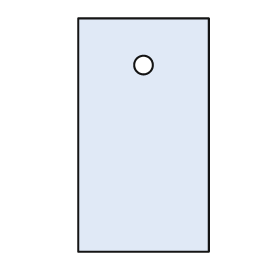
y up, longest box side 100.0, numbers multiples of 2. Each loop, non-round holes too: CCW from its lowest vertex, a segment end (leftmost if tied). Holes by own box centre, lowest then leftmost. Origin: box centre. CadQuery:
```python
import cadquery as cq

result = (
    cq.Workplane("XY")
    .moveTo(-28.0, -50.0)
    .lineTo(28.0, -50.0)
    .lineTo(28.0, 50.0)
    .lineTo(-28.0, 50.0)
    .close()
    .moveTo(0.0, 30.0)
    .circle(4.0)
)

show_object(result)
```